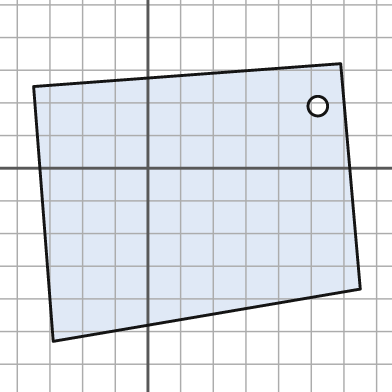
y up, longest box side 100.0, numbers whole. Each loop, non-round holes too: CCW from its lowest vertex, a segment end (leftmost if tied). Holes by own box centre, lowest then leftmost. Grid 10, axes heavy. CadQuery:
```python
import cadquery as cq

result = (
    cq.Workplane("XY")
    .moveTo(-29.0, -53.0)
    .lineTo(65.0, -37.0)
    .lineTo(59.0, 32.0)
    .lineTo(-35.0, 25.0)
    .close()
    .moveTo(52.0, 19.0)
    .circle(3.0)
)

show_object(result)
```